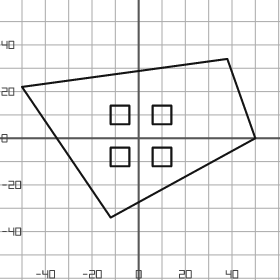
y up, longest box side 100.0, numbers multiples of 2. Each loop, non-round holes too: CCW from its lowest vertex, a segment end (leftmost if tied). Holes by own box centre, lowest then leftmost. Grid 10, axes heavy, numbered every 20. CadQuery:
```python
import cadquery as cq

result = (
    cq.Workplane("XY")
    .moveTo(-12.0, -34.0)
    .lineTo(50.0, 0.0)
    .lineTo(38.0, 34.0)
    .lineTo(-50.0, 22.0)
    .close()
    .moveTo(-12.0, -12.0)
    .lineTo(-4.0, -12.0)
    .lineTo(-4.0, -4.0)
    .lineTo(-12.0, -4.0)
    .close()
    .moveTo(6.0, -12.0)
    .lineTo(14.0, -12.0)
    .lineTo(14.0, -4.0)
    .lineTo(6.0, -4.0)
    .close()
    .moveTo(-12.0, 6.0)
    .lineTo(-4.0, 6.0)
    .lineTo(-4.0, 14.0)
    .lineTo(-12.0, 14.0)
    .close()
    .moveTo(6.0, 6.0)
    .lineTo(14.0, 6.0)
    .lineTo(14.0, 14.0)
    .lineTo(6.0, 14.0)
    .close()
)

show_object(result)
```